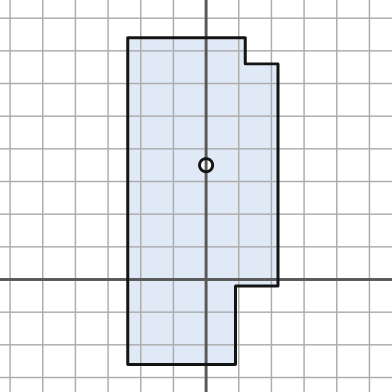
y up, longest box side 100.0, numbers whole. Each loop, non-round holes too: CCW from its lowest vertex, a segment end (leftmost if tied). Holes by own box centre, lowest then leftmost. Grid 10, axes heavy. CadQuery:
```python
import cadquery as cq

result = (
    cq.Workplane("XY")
    .moveTo(-24.0, -26.0)
    .lineTo(9.0, -26.0)
    .lineTo(9.0, -2.0)
    .lineTo(22.0, -2.0)
    .lineTo(22.0, 66.0)
    .lineTo(12.0, 66.0)
    .lineTo(12.0, 74.0)
    .lineTo(-24.0, 74.0)
    .close()
    .moveTo(0.0, 35.0)
    .circle(2.0)
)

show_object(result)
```